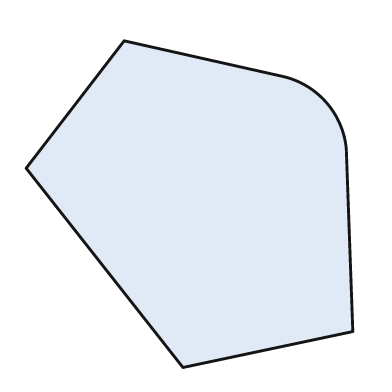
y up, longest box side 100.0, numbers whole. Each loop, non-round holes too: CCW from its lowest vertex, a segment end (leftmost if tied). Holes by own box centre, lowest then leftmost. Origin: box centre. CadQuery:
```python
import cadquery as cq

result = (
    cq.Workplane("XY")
    .moveTo(-2.0, -50.0)
    .lineTo(50.0, -39.0)
    .lineTo(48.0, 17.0)
    .threePointArc((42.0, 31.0), (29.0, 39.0))
    .lineTo(-20.0, 50.0)
    .lineTo(-50.0, 11.0)
    .close()
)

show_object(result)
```